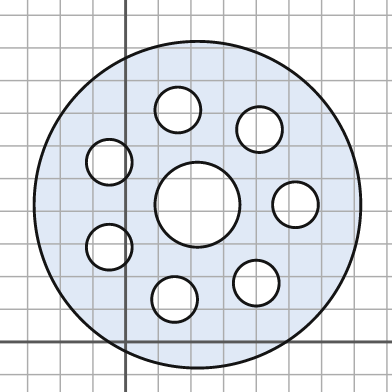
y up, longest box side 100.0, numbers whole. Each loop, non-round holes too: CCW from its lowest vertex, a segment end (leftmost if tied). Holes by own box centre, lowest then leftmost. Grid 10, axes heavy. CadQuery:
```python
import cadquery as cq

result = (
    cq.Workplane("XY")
    .moveTo(22.0, 42.0)
    .circle(50.0)
    .moveTo(15.0, 13.0)
    .circle(7.0)
    .moveTo(40.0, 18.0)
    .circle(7.0)
    .moveTo(-5.0, 29.0)
    .circle(7.0)
    .moveTo(22.0, 42.0)
    .circle(13.0)
    .moveTo(52.0, 42.0)
    .circle(7.0)
    .moveTo(-5.0, 55.0)
    .circle(7.0)
    .moveTo(41.0, 65.0)
    .circle(7.0)
    .moveTo(16.0, 71.0)
    .circle(7.0)
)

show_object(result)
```